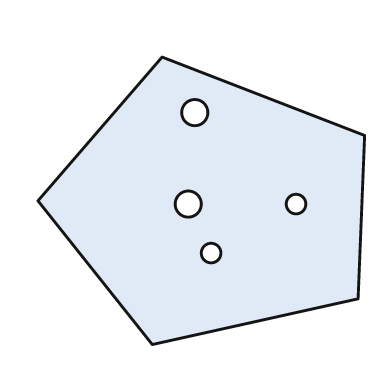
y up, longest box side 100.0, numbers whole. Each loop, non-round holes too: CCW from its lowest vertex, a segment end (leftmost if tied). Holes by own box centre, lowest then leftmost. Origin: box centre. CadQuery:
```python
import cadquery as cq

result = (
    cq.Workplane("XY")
    .moveTo(-15.0, -44.0)
    .lineTo(48.0, -30.0)
    .lineTo(50.0, 20.0)
    .lineTo(-12.0, 44.0)
    .lineTo(-50.0, 0.0)
    .close()
    .moveTo(3.0, -16.0)
    .circle(3.0)
    .moveTo(-4.0, -1.0)
    .circle(4.0)
    .moveTo(29.0, -1.0)
    .circle(3.0)
    .moveTo(-2.0, 27.0)
    .circle(4.0)
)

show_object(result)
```